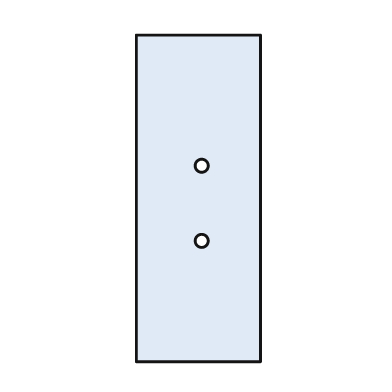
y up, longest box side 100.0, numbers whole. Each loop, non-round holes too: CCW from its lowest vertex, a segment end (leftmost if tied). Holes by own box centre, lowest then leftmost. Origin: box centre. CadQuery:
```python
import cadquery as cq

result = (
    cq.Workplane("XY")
    .moveTo(-19.0, -50.0)
    .lineTo(19.0, -50.0)
    .lineTo(19.0, 50.0)
    .lineTo(-19.0, 50.0)
    .close()
    .moveTo(1.0, -13.0)
    .circle(2.0)
    .moveTo(1.0, 10.0)
    .circle(2.0)
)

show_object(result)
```